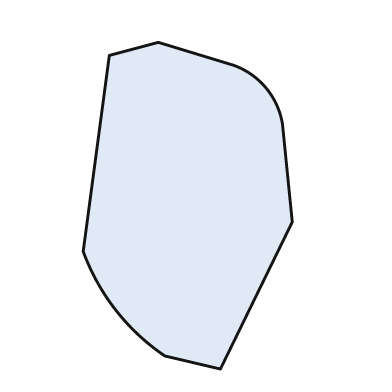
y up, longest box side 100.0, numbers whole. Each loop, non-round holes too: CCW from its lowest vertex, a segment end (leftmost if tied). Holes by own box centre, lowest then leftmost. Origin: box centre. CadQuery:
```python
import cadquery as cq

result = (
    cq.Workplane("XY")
    .moveTo(10.0, -50.0)
    .lineTo(32.0, -5.0)
    .lineTo(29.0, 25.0)
    .threePointArc((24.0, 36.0), (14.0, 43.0))
    .lineTo(-9.0, 50.0)
    .lineTo(-24.0, 46.0)
    .lineTo(-32.0, -14.0)
    .threePointArc((-22.0, -32.0), (-7.0, -46.0))
    .close()
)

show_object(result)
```